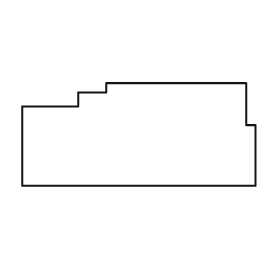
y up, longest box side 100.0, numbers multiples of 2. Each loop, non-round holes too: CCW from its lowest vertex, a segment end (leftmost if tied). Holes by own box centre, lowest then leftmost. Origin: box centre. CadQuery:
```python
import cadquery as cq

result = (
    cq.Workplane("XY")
    .moveTo(-50.0, -22.0)
    .lineTo(50.0, -22.0)
    .lineTo(50.0, 4.0)
    .lineTo(46.0, 4.0)
    .lineTo(46.0, 22.0)
    .lineTo(-14.0, 22.0)
    .lineTo(-14.0, 18.0)
    .lineTo(-26.0, 18.0)
    .lineTo(-26.0, 12.0)
    .lineTo(-50.0, 12.0)
    .close()
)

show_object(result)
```